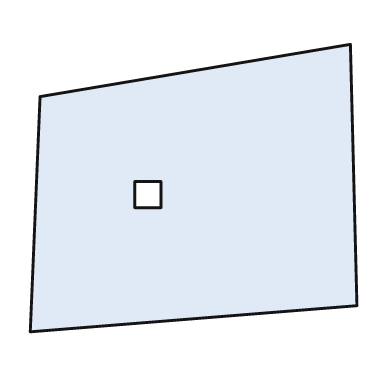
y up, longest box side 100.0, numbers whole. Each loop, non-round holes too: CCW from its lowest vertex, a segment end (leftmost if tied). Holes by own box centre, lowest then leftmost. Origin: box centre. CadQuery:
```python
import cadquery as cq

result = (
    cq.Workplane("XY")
    .moveTo(-50.0, -44.0)
    .lineTo(50.0, -36.0)
    .lineTo(48.0, 44.0)
    .lineTo(-47.0, 28.0)
    .close()
    .moveTo(-18.0, -6.0)
    .lineTo(-10.0, -6.0)
    .lineTo(-10.0, 2.0)
    .lineTo(-18.0, 2.0)
    .close()
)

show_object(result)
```